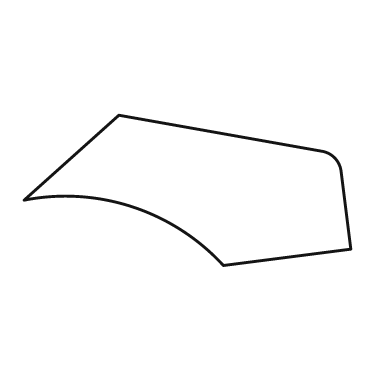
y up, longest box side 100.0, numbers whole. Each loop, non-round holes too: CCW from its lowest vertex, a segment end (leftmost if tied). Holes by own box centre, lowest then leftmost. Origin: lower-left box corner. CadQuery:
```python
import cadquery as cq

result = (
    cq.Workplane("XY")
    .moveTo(61.0, 0.0)
    .lineTo(100.0, 5.0)
    .lineTo(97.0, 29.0)
    .threePointArc((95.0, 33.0), (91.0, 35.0))
    .lineTo(29.0, 46.0)
    .lineTo(0.0, 20.0)
    .threePointArc((33.0, 18.0), (61.0, 0.0))
    .close()
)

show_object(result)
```